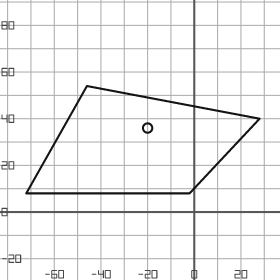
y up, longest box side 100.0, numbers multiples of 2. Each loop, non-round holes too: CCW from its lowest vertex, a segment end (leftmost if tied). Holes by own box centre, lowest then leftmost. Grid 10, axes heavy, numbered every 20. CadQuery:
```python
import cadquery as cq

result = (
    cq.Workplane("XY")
    .moveTo(-72.0, 8.0)
    .lineTo(-2.0, 8.0)
    .lineTo(28.0, 40.0)
    .lineTo(-46.0, 54.0)
    .close()
    .moveTo(-20.0, 36.0)
    .circle(2.0)
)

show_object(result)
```